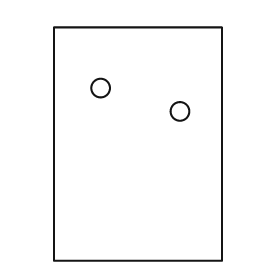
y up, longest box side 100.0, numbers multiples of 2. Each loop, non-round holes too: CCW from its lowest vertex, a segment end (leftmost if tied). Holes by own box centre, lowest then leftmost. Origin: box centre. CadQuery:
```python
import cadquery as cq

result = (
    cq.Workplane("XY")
    .moveTo(-36.0, -50.0)
    .lineTo(36.0, -50.0)
    .lineTo(36.0, 50.0)
    .lineTo(-36.0, 50.0)
    .close()
    .moveTo(18.0, 14.0)
    .circle(4.0)
    .moveTo(-16.0, 24.0)
    .circle(4.0)
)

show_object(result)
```